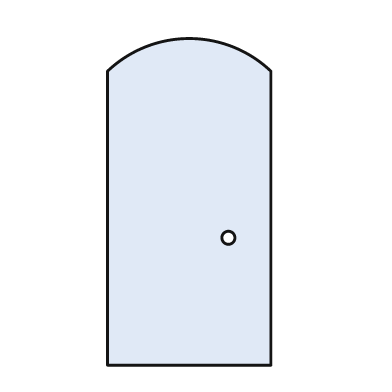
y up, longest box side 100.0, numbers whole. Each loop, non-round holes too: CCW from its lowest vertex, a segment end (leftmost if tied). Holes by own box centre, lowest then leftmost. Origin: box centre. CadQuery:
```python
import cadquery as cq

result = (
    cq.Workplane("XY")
    .moveTo(-25.0, -50.0)
    .lineTo(25.0, -50.0)
    .lineTo(25.0, 40.0)
    .threePointArc((0.0, 50.0), (-25.0, 40.0))
    .close()
    .moveTo(12.0, -11.0)
    .circle(2.0)
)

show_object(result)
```